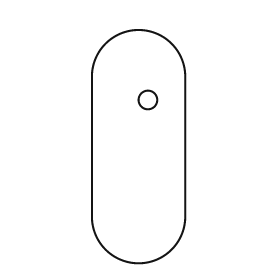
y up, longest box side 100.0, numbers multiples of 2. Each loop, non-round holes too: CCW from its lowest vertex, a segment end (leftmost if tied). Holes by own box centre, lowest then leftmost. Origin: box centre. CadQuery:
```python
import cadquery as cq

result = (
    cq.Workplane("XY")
    .moveTo(-20.0, -30.0)
    .threePointArc((0.0, -50.0), (20.0, -30.0))
    .lineTo(20.0, 30.0)
    .threePointArc((0.0, 50.0), (-20.0, 30.0))
    .close()
    .moveTo(4.0, 20.0)
    .circle(4.0)
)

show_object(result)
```